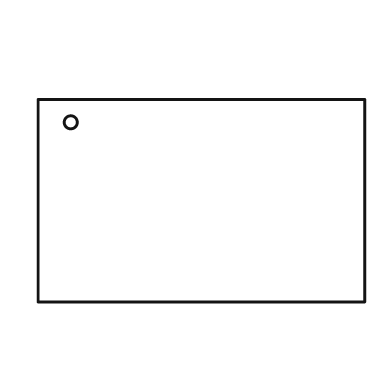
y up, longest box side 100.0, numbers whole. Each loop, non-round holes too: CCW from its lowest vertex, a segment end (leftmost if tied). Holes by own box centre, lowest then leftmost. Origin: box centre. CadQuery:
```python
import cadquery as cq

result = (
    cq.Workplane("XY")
    .moveTo(-50.0, -31.0)
    .lineTo(50.0, -31.0)
    .lineTo(50.0, 31.0)
    .lineTo(-50.0, 31.0)
    .close()
    .moveTo(-40.0, 24.0)
    .circle(2.0)
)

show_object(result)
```